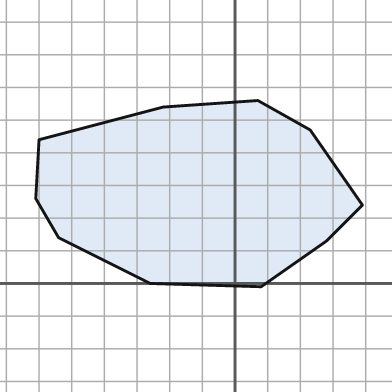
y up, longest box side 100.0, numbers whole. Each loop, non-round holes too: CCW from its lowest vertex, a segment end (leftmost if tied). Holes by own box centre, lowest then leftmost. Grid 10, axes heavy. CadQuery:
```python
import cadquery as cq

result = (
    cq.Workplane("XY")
    .moveTo(8.0, -1.0)
    .lineTo(28.0, 13.0)
    .lineTo(39.0, 24.0)
    .lineTo(23.0, 47.0)
    .lineTo(7.0, 56.0)
    .lineTo(-22.0, 54.0)
    .lineTo(-60.0, 44.0)
    .lineTo(-61.0, 26.0)
    .lineTo(-54.0, 14.0)
    .lineTo(-26.0, 0.0)
    .close()
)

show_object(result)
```